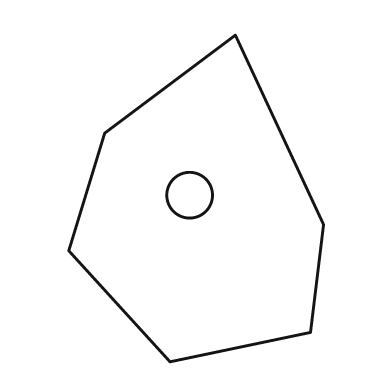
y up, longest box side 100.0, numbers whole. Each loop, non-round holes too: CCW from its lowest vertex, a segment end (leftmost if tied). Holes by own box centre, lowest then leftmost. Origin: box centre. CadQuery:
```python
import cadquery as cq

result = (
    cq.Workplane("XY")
    .moveTo(-8.0, -50.0)
    .lineTo(35.0, -41.0)
    .lineTo(39.0, -8.0)
    .lineTo(12.0, 50.0)
    .lineTo(-28.0, 20.0)
    .lineTo(-39.0, -16.0)
    .close()
    .moveTo(-2.0, 1.0)
    .circle(7.0)
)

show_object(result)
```